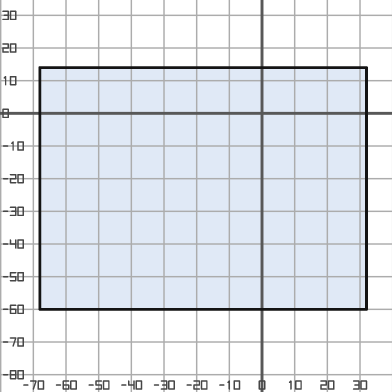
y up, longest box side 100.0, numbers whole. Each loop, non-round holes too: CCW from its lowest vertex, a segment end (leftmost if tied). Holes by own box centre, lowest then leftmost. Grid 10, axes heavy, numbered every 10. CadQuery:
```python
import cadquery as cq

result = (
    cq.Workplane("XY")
    .moveTo(-68.0, -60.0)
    .lineTo(32.0, -60.0)
    .lineTo(32.0, 14.0)
    .lineTo(-68.0, 14.0)
    .close()
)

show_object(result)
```